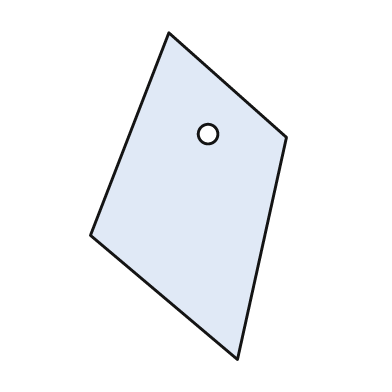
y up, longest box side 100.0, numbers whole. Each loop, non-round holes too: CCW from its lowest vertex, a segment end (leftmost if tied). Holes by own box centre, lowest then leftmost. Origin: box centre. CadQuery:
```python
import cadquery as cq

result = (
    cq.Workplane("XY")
    .moveTo(15.0, -50.0)
    .lineTo(30.0, 18.0)
    .lineTo(-6.0, 50.0)
    .lineTo(-30.0, -12.0)
    .close()
    .moveTo(6.0, 19.0)
    .circle(3.0)
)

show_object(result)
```